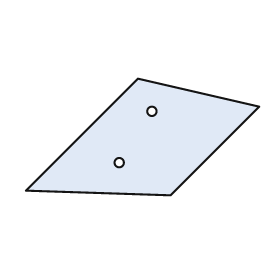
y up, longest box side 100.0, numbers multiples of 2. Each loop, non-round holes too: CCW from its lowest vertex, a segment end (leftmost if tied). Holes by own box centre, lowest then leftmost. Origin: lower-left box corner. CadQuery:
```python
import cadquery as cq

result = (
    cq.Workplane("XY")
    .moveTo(62.0, 0.0)
    .lineTo(100.0, 38.0)
    .lineTo(48.0, 50.0)
    .lineTo(0.0, 2.0)
    .close()
    .moveTo(40.0, 14.0)
    .circle(2.0)
    .moveTo(54.0, 36.0)
    .circle(2.0)
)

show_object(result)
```